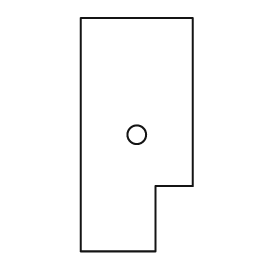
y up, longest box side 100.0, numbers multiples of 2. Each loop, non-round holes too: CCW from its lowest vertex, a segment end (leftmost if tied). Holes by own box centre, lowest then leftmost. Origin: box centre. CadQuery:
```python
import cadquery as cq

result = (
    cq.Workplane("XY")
    .moveTo(-24.0, -50.0)
    .lineTo(8.0, -50.0)
    .lineTo(8.0, -22.0)
    .lineTo(24.0, -22.0)
    .lineTo(24.0, 50.0)
    .lineTo(-24.0, 50.0)
    .close()
    .moveTo(0.0, 0.0)
    .circle(4.0)
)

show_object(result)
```